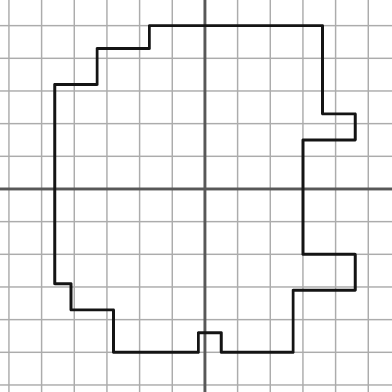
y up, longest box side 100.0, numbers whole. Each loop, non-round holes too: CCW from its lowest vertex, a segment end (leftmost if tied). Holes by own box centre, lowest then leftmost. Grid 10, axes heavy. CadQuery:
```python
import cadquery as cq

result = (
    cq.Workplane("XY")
    .moveTo(-28.0, -50.0)
    .lineTo(-2.0, -50.0)
    .lineTo(-2.0, -44.0)
    .lineTo(5.0, -44.0)
    .lineTo(5.0, -50.0)
    .lineTo(27.0, -50.0)
    .lineTo(27.0, -31.0)
    .lineTo(46.0, -31.0)
    .lineTo(46.0, -20.0)
    .lineTo(30.0, -20.0)
    .lineTo(30.0, 15.0)
    .lineTo(46.0, 15.0)
    .lineTo(46.0, 23.0)
    .lineTo(36.0, 23.0)
    .lineTo(36.0, 50.0)
    .lineTo(-17.0, 50.0)
    .lineTo(-17.0, 43.0)
    .lineTo(-33.0, 43.0)
    .lineTo(-33.0, 32.0)
    .lineTo(-46.0, 32.0)
    .lineTo(-46.0, -29.0)
    .lineTo(-41.0, -29.0)
    .lineTo(-41.0, -37.0)
    .lineTo(-28.0, -37.0)
    .close()
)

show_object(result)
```